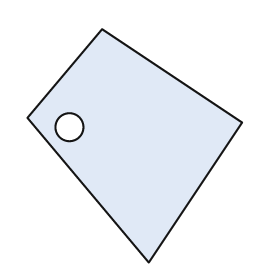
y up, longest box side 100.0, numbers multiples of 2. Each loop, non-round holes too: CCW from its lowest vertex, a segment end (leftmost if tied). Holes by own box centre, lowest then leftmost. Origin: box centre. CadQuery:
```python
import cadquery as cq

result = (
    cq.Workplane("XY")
    .moveTo(6.0, -50.0)
    .lineTo(46.0, 10.0)
    .lineTo(-14.0, 50.0)
    .lineTo(-46.0, 12.0)
    .close()
    .moveTo(-28.0, 8.0)
    .circle(6.0)
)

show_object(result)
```